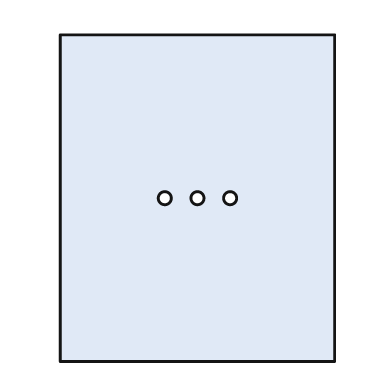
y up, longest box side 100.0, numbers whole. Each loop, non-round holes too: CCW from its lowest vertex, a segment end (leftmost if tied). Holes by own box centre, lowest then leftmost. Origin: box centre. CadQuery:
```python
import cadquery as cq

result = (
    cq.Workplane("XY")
    .moveTo(-42.0, -50.0)
    .lineTo(42.0, -50.0)
    .lineTo(42.0, 50.0)
    .lineTo(-42.0, 50.0)
    .close()
    .moveTo(-10.0, 0.0)
    .circle(2.0)
    .moveTo(0.0, 0.0)
    .circle(2.0)
    .moveTo(10.0, 0.0)
    .circle(2.0)
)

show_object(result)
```